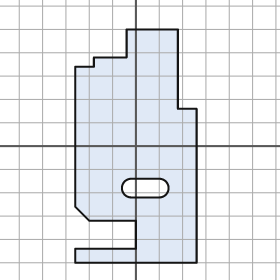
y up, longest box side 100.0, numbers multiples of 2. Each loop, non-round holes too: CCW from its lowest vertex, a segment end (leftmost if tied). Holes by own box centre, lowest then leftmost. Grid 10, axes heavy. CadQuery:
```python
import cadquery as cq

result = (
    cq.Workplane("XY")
    .moveTo(-26.0, -50.0)
    .lineTo(26.0, -50.0)
    .lineTo(26.0, 16.0)
    .lineTo(18.0, 16.0)
    .lineTo(18.0, 50.0)
    .lineTo(-4.0, 50.0)
    .lineTo(-4.0, 38.0)
    .lineTo(-18.0, 38.0)
    .lineTo(-18.0, 34.0)
    .lineTo(-26.0, 34.0)
    .lineTo(-26.0, -26.0)
    .lineTo(-20.0, -32.0)
    .lineTo(0.0, -32.0)
    .lineTo(0.0, -44.0)
    .lineTo(-26.0, -44.0)
    .close()
    .moveTo(-2.0, -22.0)
    .lineTo(10.0, -22.0)
    .threePointArc((14.0, -18.0), (10.0, -14.0))
    .lineTo(-2.0, -14.0)
    .threePointArc((-6.0, -18.0), (-2.0, -22.0))
    .close()
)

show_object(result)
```